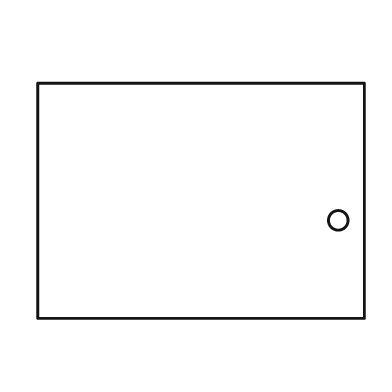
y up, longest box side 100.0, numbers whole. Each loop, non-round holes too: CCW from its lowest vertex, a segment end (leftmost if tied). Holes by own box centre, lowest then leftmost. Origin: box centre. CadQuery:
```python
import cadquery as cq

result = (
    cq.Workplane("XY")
    .moveTo(-50.0, -36.0)
    .lineTo(50.0, -36.0)
    .lineTo(50.0, 36.0)
    .lineTo(-50.0, 36.0)
    .close()
    .moveTo(42.0, -6.0)
    .circle(3.0)
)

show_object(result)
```